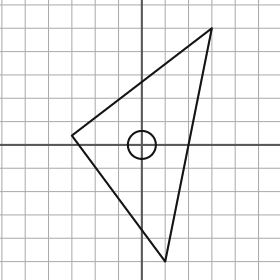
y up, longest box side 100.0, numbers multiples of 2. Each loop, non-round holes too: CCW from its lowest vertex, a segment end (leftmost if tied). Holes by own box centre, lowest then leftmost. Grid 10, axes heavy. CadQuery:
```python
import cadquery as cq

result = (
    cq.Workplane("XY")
    .moveTo(10.0, -50.0)
    .lineTo(30.0, 50.0)
    .lineTo(-30.0, 4.0)
    .close()
    .moveTo(0.0, 0.0)
    .circle(6.0)
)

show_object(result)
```